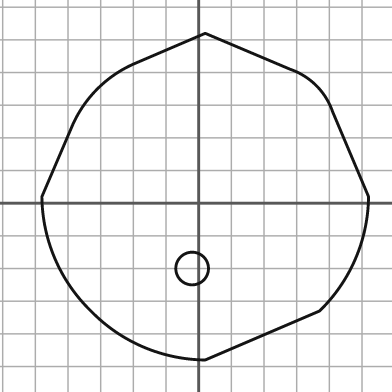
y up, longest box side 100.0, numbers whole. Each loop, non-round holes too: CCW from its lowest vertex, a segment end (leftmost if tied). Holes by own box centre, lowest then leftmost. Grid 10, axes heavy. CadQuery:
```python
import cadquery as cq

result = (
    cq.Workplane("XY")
    .moveTo(2.0, -48.0)
    .lineTo(37.0, -33.0)
    .threePointArc((48.0, -17.0), (52.0, 2.0))
    .lineTo(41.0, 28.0)
    .threePointArc((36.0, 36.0), (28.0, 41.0))
    .lineTo(2.0, 52.0)
    .lineTo(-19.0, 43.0)
    .threePointArc((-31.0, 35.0), (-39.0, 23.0))
    .lineTo(-48.0, 2.0)
    .threePointArc((-44.0, -17.0), (-33.0, -33.0))
    .threePointArc((-17.0, -44.0), (2.0, -48.0))
    .close()
    .moveTo(-2.0, -20.0)
    .circle(5.0)
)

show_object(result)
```